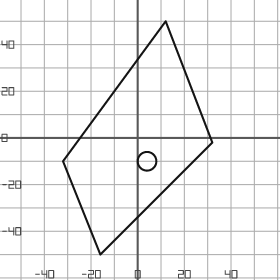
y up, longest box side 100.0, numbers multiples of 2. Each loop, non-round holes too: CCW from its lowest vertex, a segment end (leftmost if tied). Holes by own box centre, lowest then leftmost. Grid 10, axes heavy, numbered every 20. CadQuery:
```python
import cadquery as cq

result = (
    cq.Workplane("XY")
    .moveTo(-16.0, -50.0)
    .lineTo(32.0, -2.0)
    .lineTo(12.0, 50.0)
    .lineTo(-32.0, -10.0)
    .close()
    .moveTo(4.0, -10.0)
    .circle(4.0)
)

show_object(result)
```